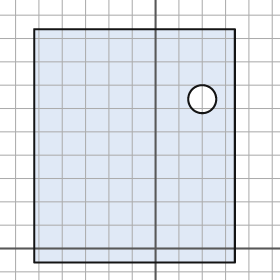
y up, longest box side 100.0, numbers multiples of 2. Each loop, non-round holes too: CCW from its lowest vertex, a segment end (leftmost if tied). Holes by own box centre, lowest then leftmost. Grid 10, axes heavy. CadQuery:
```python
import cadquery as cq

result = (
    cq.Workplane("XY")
    .moveTo(-52.0, -6.0)
    .lineTo(34.0, -6.0)
    .lineTo(34.0, 94.0)
    .lineTo(-52.0, 94.0)
    .close()
    .moveTo(20.0, 64.0)
    .circle(6.0)
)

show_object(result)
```